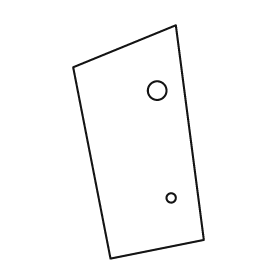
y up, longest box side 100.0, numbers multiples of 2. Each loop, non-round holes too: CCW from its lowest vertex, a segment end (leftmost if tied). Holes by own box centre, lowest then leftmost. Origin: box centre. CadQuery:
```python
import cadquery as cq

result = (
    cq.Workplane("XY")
    .moveTo(-12.0, -50.0)
    .lineTo(28.0, -42.0)
    .lineTo(16.0, 50.0)
    .lineTo(-28.0, 32.0)
    .close()
    .moveTo(14.0, -24.0)
    .circle(2.0)
    .moveTo(8.0, 22.0)
    .circle(4.0)
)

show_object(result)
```